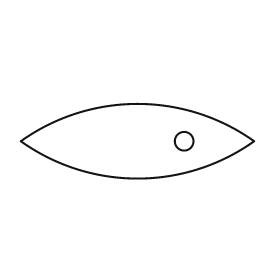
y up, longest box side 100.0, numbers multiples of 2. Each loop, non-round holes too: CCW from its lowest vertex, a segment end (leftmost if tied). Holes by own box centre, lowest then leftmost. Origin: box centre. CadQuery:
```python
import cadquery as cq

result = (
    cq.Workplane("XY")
    .moveTo(-50.0, 0.0)
    .threePointArc((0.0, -16.0), (50.0, 0.0))
    .threePointArc((0.0, 16.0), (-50.0, 0.0))
    .close()
    .moveTo(20.0, 0.0)
    .circle(4.0)
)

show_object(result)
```